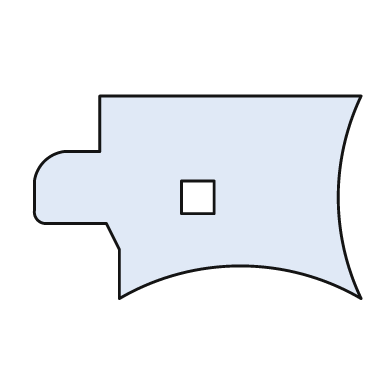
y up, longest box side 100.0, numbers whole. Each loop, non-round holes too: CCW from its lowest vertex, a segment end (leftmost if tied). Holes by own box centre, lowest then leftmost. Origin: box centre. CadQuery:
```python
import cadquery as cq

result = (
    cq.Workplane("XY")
    .moveTo(-24.0, -31.0)
    .threePointArc((13.0, -21.0), (50.0, -31.0))
    .threePointArc((43.0, 0.0), (50.0, 31.0))
    .lineTo(-30.0, 31.0)
    .lineTo(-30.0, 14.0)
    .lineTo(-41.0, 14.0)
    .threePointArc((-47.0, 11.0), (-50.0, 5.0))
    .lineTo(-50.0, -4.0)
    .threePointArc((-49.0, -7.0), (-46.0, -8.0))
    .lineTo(-28.0, -8.0)
    .lineTo(-24.0, -16.0)
    .close()
    .moveTo(-5.0, -5.0)
    .lineTo(5.0, -5.0)
    .lineTo(5.0, 5.0)
    .lineTo(-5.0, 5.0)
    .close()
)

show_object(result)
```